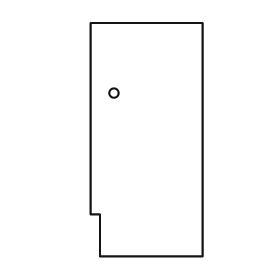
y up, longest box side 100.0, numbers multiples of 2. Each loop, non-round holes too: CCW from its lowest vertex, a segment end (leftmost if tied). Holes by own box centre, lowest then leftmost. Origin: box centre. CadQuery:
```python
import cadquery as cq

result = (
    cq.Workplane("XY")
    .moveTo(-20.0, -50.0)
    .lineTo(24.0, -50.0)
    .lineTo(24.0, 50.0)
    .lineTo(-24.0, 50.0)
    .lineTo(-24.0, -32.0)
    .lineTo(-20.0, -32.0)
    .close()
    .moveTo(-14.0, 20.0)
    .circle(2.0)
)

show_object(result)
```